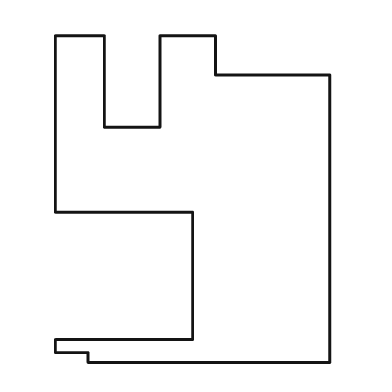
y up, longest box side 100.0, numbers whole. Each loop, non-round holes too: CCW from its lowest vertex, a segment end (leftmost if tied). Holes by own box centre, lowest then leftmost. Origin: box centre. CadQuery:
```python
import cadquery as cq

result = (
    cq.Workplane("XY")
    .moveTo(-32.0, -50.0)
    .lineTo(42.0, -50.0)
    .lineTo(42.0, 38.0)
    .lineTo(7.0, 38.0)
    .lineTo(7.0, 50.0)
    .lineTo(-10.0, 50.0)
    .lineTo(-10.0, 22.0)
    .lineTo(-27.0, 22.0)
    .lineTo(-27.0, 50.0)
    .lineTo(-42.0, 50.0)
    .lineTo(-42.0, -4.0)
    .lineTo(0.0, -4.0)
    .lineTo(0.0, -43.0)
    .lineTo(-42.0, -43.0)
    .lineTo(-42.0, -47.0)
    .lineTo(-32.0, -47.0)
    .close()
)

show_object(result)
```